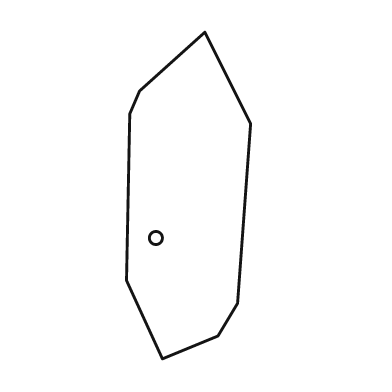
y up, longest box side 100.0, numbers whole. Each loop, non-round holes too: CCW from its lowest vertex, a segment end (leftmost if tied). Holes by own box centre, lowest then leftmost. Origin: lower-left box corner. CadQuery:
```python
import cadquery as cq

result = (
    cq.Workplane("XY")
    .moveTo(11.0, 0.0)
    .lineTo(28.0, 7.0)
    .lineTo(34.0, 17.0)
    .lineTo(38.0, 72.0)
    .lineTo(24.0, 100.0)
    .lineTo(4.0, 82.0)
    .lineTo(1.0, 75.0)
    .lineTo(0.0, 24.0)
    .close()
    .moveTo(9.0, 37.0)
    .circle(2.0)
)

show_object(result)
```